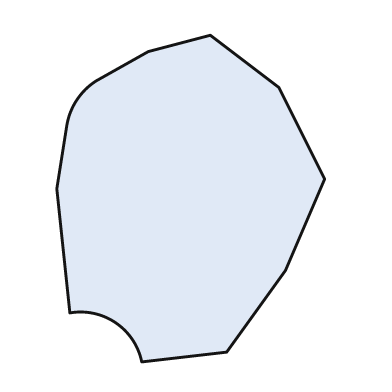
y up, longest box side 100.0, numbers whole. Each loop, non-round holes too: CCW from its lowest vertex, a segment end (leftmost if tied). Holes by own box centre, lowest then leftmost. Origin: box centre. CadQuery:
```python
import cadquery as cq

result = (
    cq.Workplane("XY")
    .moveTo(-15.0, -50.0)
    .lineTo(11.0, -47.0)
    .lineTo(29.0, -22.0)
    .lineTo(41.0, 6.0)
    .lineTo(27.0, 34.0)
    .lineTo(6.0, 50.0)
    .lineTo(-13.0, 45.0)
    .lineTo(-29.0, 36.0)
    .threePointArc((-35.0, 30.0), (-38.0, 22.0))
    .lineTo(-41.0, 3.0)
    .lineTo(-37.0, -35.0)
    .threePointArc((-23.0, -38.0), (-15.0, -50.0))
    .close()
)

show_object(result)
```